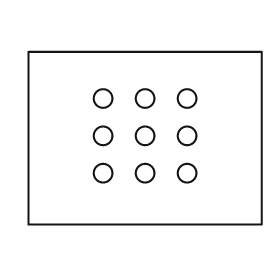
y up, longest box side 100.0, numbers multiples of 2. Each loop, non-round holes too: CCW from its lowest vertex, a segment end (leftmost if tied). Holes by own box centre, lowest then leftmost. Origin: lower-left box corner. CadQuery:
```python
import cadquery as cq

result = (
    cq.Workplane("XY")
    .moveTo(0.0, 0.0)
    .lineTo(100.0, 0.0)
    .lineTo(100.0, 74.0)
    .lineTo(0.0, 74.0)
    .close()
    .moveTo(32.0, 22.0)
    .circle(4.0)
    .moveTo(50.0, 22.0)
    .circle(4.0)
    .moveTo(68.0, 22.0)
    .circle(4.0)
    .moveTo(32.0, 38.0)
    .circle(4.0)
    .moveTo(50.0, 38.0)
    .circle(4.0)
    .moveTo(68.0, 38.0)
    .circle(4.0)
    .moveTo(32.0, 54.0)
    .circle(4.0)
    .moveTo(50.0, 54.0)
    .circle(4.0)
    .moveTo(68.0, 54.0)
    .circle(4.0)
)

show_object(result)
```